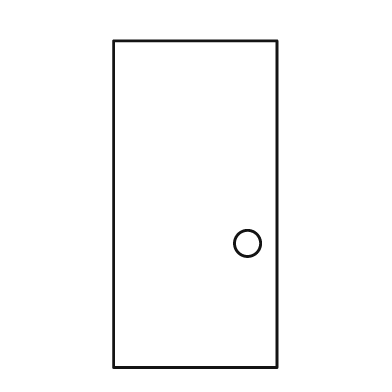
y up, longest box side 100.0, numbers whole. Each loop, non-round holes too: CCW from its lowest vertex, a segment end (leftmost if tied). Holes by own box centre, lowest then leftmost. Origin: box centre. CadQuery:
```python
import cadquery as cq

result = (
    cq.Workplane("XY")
    .moveTo(-25.0, -50.0)
    .lineTo(25.0, -50.0)
    .lineTo(25.0, 50.0)
    .lineTo(-25.0, 50.0)
    .close()
    .moveTo(16.0, -12.0)
    .circle(4.0)
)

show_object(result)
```